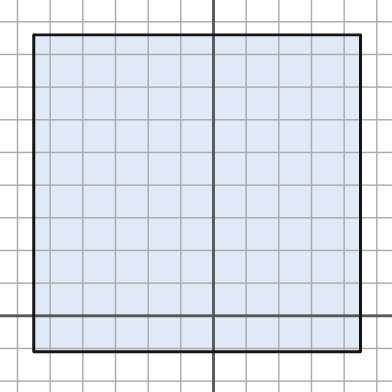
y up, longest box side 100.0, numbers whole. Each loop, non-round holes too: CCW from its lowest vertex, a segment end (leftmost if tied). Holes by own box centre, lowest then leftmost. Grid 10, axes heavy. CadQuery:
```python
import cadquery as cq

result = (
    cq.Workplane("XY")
    .moveTo(-55.0, -11.0)
    .lineTo(45.0, -11.0)
    .lineTo(45.0, 86.0)
    .lineTo(-55.0, 86.0)
    .close()
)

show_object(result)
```